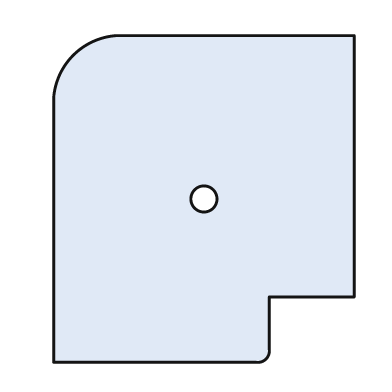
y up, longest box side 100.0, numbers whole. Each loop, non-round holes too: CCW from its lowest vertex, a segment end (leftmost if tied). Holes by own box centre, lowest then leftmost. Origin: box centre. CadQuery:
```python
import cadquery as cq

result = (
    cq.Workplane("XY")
    .moveTo(-46.0, -50.0)
    .lineTo(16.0, -50.0)
    .threePointArc((19.0, -49.0), (20.0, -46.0))
    .lineTo(20.0, -30.0)
    .lineTo(46.0, -30.0)
    .lineTo(46.0, 50.0)
    .lineTo(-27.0, 50.0)
    .threePointArc((-40.0, 44.0), (-46.0, 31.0))
    .close()
    .moveTo(0.0, 0.0)
    .circle(4.0)
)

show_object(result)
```